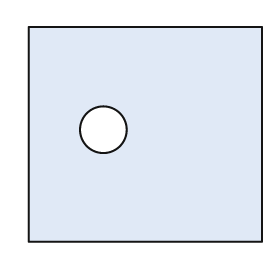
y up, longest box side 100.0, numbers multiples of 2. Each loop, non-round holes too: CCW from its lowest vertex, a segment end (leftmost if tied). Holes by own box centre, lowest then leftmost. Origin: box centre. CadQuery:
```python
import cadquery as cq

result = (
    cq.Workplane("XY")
    .moveTo(-50.0, -46.0)
    .lineTo(50.0, -46.0)
    .lineTo(50.0, 46.0)
    .lineTo(-50.0, 46.0)
    .close()
    .moveTo(-18.0, 2.0)
    .circle(10.0)
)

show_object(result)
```